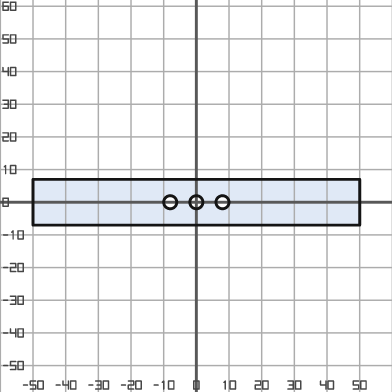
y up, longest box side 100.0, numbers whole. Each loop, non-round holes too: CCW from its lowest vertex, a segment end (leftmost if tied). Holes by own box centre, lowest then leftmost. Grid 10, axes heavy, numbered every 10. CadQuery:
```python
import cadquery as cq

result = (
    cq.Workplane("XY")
    .moveTo(-50.0, -7.0)
    .lineTo(50.0, -7.0)
    .lineTo(50.0, 7.0)
    .lineTo(-50.0, 7.0)
    .close()
    .moveTo(-8.0, 0.0)
    .circle(2.0)
    .moveTo(0.0, 0.0)
    .circle(2.0)
    .moveTo(8.0, 0.0)
    .circle(2.0)
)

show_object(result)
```